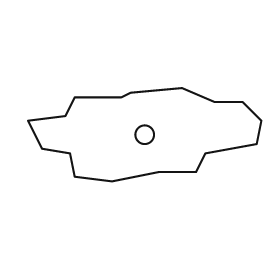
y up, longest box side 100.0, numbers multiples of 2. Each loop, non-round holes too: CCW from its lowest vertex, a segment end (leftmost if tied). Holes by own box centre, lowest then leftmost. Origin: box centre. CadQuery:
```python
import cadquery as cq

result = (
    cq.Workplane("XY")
    .moveTo(-14.0, -20.0)
    .lineTo(6.0, -16.0)
    .lineTo(22.0, -16.0)
    .lineTo(26.0, -8.0)
    .lineTo(48.0, -4.0)
    .lineTo(50.0, 6.0)
    .lineTo(42.0, 14.0)
    .lineTo(30.0, 14.0)
    .lineTo(16.0, 20.0)
    .lineTo(-6.0, 18.0)
    .lineTo(-10.0, 16.0)
    .lineTo(-30.0, 16.0)
    .lineTo(-34.0, 8.0)
    .lineTo(-50.0, 6.0)
    .lineTo(-44.0, -6.0)
    .lineTo(-32.0, -8.0)
    .lineTo(-30.0, -18.0)
    .close()
    .moveTo(0.0, 0.0)
    .circle(4.0)
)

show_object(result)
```